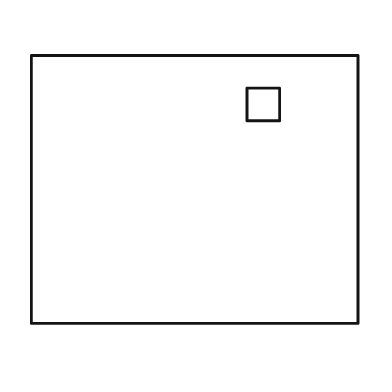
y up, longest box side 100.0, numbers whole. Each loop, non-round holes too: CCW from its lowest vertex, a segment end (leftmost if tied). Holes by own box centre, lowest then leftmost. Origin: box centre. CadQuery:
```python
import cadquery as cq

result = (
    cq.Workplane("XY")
    .moveTo(-50.0, -41.0)
    .lineTo(50.0, -41.0)
    .lineTo(50.0, 41.0)
    .lineTo(-50.0, 41.0)
    .close()
    .moveTo(16.0, 21.0)
    .lineTo(26.0, 21.0)
    .lineTo(26.0, 31.0)
    .lineTo(16.0, 31.0)
    .close()
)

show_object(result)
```